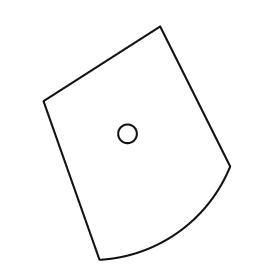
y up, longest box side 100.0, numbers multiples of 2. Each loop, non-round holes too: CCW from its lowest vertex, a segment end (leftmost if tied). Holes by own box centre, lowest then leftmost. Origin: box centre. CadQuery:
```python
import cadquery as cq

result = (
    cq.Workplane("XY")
    .moveTo(-16.0, -50.0)
    .threePointArc((18.0, -38.0), (40.0, -10.0))
    .lineTo(10.0, 50.0)
    .lineTo(-40.0, 18.0)
    .close()
    .moveTo(-4.0, 4.0)
    .circle(4.0)
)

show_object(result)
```